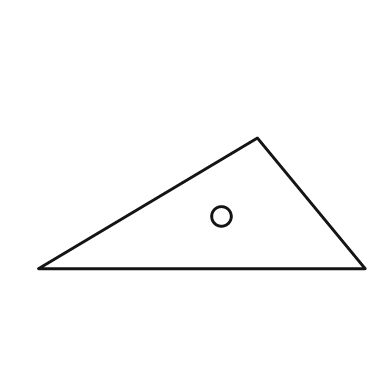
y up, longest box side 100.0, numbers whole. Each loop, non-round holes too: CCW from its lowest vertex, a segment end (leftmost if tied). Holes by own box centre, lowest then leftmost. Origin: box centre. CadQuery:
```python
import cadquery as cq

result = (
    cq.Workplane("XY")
    .moveTo(-50.0, -20.0)
    .lineTo(50.0, -20.0)
    .lineTo(17.0, 20.0)
    .close()
    .moveTo(6.0, -4.0)
    .circle(3.0)
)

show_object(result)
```